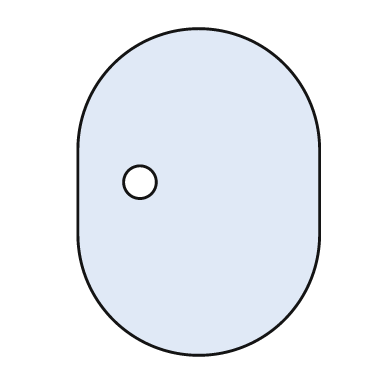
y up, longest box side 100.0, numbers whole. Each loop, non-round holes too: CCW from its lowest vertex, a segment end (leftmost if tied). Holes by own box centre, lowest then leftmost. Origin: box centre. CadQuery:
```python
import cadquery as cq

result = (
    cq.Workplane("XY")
    .moveTo(-37.0, -13.0)
    .threePointArc((0.0, -50.0), (37.0, -13.0))
    .lineTo(37.0, 13.0)
    .threePointArc((0.0, 50.0), (-37.0, 13.0))
    .close()
    .moveTo(-18.0, 3.0)
    .circle(5.0)
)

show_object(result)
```